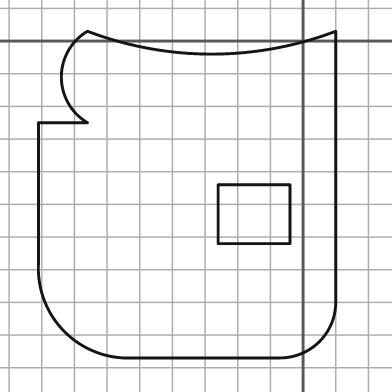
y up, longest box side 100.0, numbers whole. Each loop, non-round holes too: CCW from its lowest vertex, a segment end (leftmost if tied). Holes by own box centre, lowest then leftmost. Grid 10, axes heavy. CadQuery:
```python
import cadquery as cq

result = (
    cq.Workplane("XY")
    .moveTo(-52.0, -97.0)
    .lineTo(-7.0, -97.0)
    .threePointArc((5.0, -92.0), (10.0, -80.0))
    .lineTo(10.0, 3.0)
    .threePointArc((-28.0, -4.0), (-66.0, 3.0))
    .threePointArc((-74.0, -11.0), (-66.0, -25.0))
    .lineTo(-81.0, -25.0)
    .lineTo(-81.0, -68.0)
    .threePointArc((-73.0, -89.0), (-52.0, -97.0))
    .close()
    .moveTo(-26.0, -62.0)
    .lineTo(-4.0, -62.0)
    .lineTo(-4.0, -44.0)
    .lineTo(-26.0, -44.0)
    .close()
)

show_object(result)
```